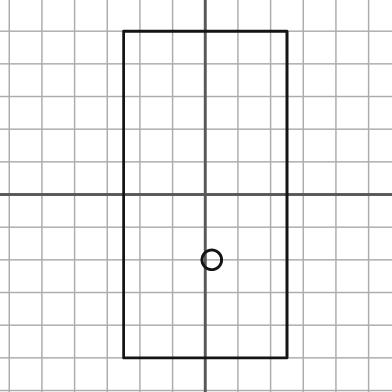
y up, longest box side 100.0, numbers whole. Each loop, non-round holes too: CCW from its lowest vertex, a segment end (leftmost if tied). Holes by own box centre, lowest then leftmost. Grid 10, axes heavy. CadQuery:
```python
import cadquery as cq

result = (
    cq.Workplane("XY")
    .moveTo(-25.0, -50.0)
    .lineTo(25.0, -50.0)
    .lineTo(25.0, 50.0)
    .lineTo(-25.0, 50.0)
    .close()
    .moveTo(2.0, -20.0)
    .circle(3.0)
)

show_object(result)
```